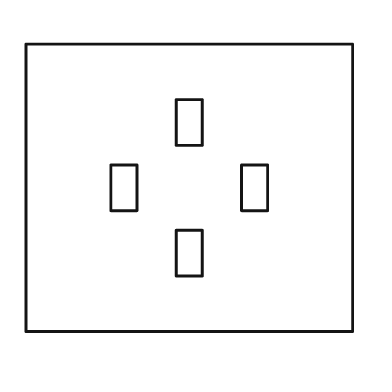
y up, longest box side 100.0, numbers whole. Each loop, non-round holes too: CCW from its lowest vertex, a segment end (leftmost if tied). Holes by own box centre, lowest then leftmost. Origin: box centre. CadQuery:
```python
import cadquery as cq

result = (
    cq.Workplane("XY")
    .moveTo(-50.0, -44.0)
    .lineTo(50.0, -44.0)
    .lineTo(50.0, 44.0)
    .lineTo(-50.0, 44.0)
    .close()
    .moveTo(-4.0, -27.0)
    .lineTo(4.0, -27.0)
    .lineTo(4.0, -13.0)
    .lineTo(-4.0, -13.0)
    .close()
    .moveTo(-24.0, -7.0)
    .lineTo(-16.0, -7.0)
    .lineTo(-16.0, 7.0)
    .lineTo(-24.0, 7.0)
    .close()
    .moveTo(16.0, -7.0)
    .lineTo(24.0, -7.0)
    .lineTo(24.0, 7.0)
    .lineTo(16.0, 7.0)
    .close()
    .moveTo(-4.0, 13.0)
    .lineTo(4.0, 13.0)
    .lineTo(4.0, 27.0)
    .lineTo(-4.0, 27.0)
    .close()
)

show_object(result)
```